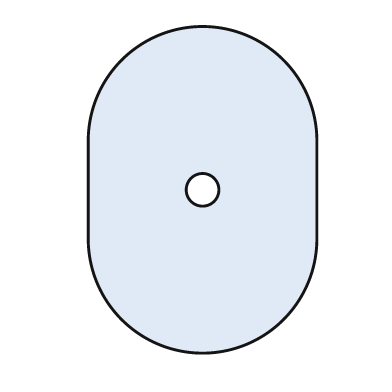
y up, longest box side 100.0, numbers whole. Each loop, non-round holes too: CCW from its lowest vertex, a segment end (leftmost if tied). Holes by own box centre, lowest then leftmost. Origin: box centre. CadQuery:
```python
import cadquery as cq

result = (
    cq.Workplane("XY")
    .moveTo(-35.0, -15.0)
    .threePointArc((0.0, -50.0), (35.0, -15.0))
    .lineTo(35.0, 15.0)
    .threePointArc((0.0, 50.0), (-35.0, 15.0))
    .close()
    .moveTo(0.0, 0.0)
    .circle(5.0)
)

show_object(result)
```